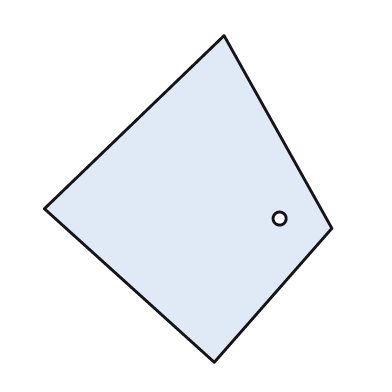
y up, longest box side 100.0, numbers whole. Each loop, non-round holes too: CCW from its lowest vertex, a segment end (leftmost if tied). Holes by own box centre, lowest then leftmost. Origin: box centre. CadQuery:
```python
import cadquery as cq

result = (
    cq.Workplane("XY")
    .moveTo(8.0, -50.0)
    .lineTo(44.0, -9.0)
    .lineTo(11.0, 50.0)
    .lineTo(-44.0, -3.0)
    .close()
    .moveTo(28.0, -6.0)
    .circle(2.0)
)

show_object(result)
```